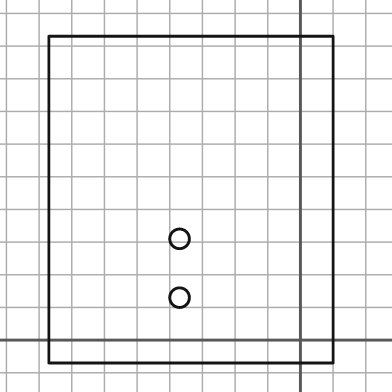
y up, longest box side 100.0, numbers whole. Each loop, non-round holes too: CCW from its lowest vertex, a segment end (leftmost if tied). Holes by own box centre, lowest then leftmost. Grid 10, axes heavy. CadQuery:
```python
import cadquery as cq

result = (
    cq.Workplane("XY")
    .moveTo(-77.0, -7.0)
    .lineTo(10.0, -7.0)
    .lineTo(10.0, 93.0)
    .lineTo(-77.0, 93.0)
    .close()
    .moveTo(-37.0, 13.0)
    .circle(3.0)
    .moveTo(-37.0, 31.0)
    .circle(3.0)
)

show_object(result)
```